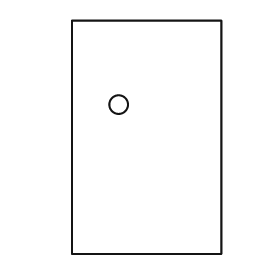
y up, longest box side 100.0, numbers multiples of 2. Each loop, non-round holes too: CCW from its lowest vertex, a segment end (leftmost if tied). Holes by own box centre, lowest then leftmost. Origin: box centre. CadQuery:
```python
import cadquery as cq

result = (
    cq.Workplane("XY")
    .moveTo(-32.0, -50.0)
    .lineTo(32.0, -50.0)
    .lineTo(32.0, 50.0)
    .lineTo(-32.0, 50.0)
    .close()
    .moveTo(-12.0, 14.0)
    .circle(4.0)
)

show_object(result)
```